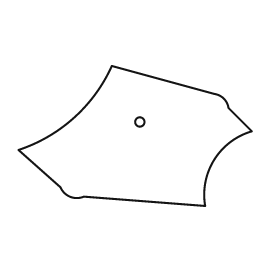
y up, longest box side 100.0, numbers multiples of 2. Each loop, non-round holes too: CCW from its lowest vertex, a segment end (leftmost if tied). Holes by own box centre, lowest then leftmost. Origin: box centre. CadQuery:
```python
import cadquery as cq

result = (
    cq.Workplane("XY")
    .moveTo(30.0, -30.0)
    .threePointArc((34.0, -10.0), (50.0, 2.0))
    .lineTo(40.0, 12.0)
    .threePointArc((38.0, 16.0), (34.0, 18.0))
    .lineTo(-10.0, 30.0)
    .threePointArc((-26.0, 8.0), (-50.0, -6.0))
    .lineTo(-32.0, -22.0)
    .threePointArc((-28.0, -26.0), (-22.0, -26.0))
    .close()
    .moveTo(2.0, 6.0)
    .circle(2.0)
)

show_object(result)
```